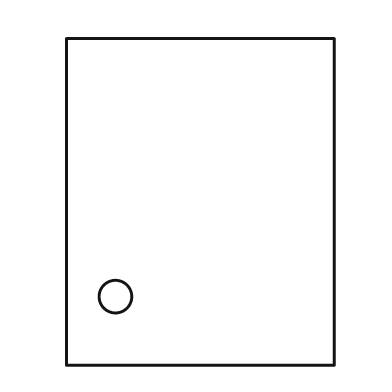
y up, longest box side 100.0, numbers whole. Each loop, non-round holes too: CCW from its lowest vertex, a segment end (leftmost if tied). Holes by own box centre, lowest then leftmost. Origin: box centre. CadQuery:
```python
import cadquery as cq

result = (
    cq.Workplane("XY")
    .moveTo(-41.0, -50.0)
    .lineTo(41.0, -50.0)
    .lineTo(41.0, 50.0)
    .lineTo(-41.0, 50.0)
    .close()
    .moveTo(-26.0, -29.0)
    .circle(5.0)
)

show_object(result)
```